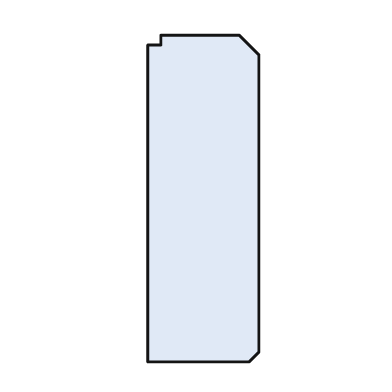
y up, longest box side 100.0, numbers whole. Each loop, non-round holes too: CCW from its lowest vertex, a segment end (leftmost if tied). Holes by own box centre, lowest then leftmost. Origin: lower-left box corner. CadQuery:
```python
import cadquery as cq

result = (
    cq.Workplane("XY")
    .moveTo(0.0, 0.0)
    .lineTo(31.0, 0.0)
    .lineTo(34.0, 3.0)
    .lineTo(34.0, 94.0)
    .lineTo(28.0, 100.0)
    .lineTo(4.0, 100.0)
    .lineTo(4.0, 97.0)
    .lineTo(0.0, 97.0)
    .close()
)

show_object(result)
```